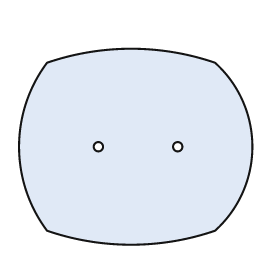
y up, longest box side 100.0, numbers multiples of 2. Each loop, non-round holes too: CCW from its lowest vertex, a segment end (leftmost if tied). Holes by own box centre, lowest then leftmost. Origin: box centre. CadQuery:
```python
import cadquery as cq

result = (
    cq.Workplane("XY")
    .moveTo(-38.0, -36.0)
    .threePointArc((-2.0, -42.0), (34.0, -36.0))
    .threePointArc((50.0, 0.0), (34.0, 36.0))
    .threePointArc((-2.0, 42.0), (-38.0, 36.0))
    .threePointArc((-50.0, 0.0), (-38.0, -36.0))
    .close()
    .moveTo(-16.0, 0.0)
    .circle(2.0)
    .moveTo(18.0, 0.0)
    .circle(2.0)
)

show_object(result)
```